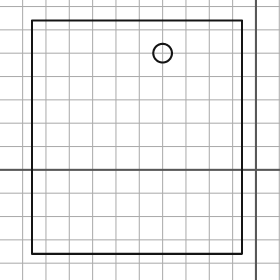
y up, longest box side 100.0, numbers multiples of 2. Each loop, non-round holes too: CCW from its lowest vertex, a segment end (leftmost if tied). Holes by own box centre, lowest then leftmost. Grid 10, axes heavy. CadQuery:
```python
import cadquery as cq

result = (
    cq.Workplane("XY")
    .moveTo(-96.0, -36.0)
    .lineTo(-6.0, -36.0)
    .lineTo(-6.0, 64.0)
    .lineTo(-96.0, 64.0)
    .close()
    .moveTo(-40.0, 50.0)
    .circle(4.0)
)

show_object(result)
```